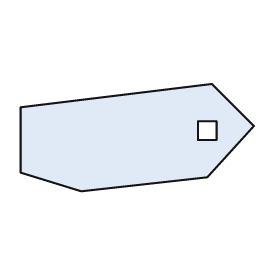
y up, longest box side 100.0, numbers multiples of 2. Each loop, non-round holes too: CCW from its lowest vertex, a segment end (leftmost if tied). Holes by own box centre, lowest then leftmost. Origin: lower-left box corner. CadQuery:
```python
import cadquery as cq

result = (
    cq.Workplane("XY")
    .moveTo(26.0, 0.0)
    .lineTo(80.0, 6.0)
    .lineTo(100.0, 28.0)
    .lineTo(82.0, 46.0)
    .lineTo(0.0, 36.0)
    .lineTo(0.0, 8.0)
    .close()
    .moveTo(76.0, 22.0)
    .lineTo(84.0, 22.0)
    .lineTo(84.0, 30.0)
    .lineTo(76.0, 30.0)
    .close()
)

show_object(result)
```